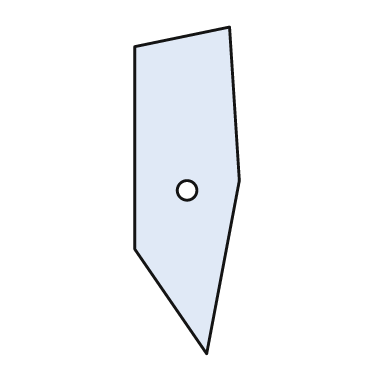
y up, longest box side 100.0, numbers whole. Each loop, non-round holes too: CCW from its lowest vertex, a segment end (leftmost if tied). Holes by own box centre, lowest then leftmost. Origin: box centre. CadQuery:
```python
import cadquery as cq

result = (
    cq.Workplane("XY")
    .moveTo(6.0, -50.0)
    .lineTo(16.0, 3.0)
    .lineTo(13.0, 50.0)
    .lineTo(-16.0, 44.0)
    .lineTo(-16.0, -18.0)
    .close()
    .moveTo(0.0, 0.0)
    .circle(3.0)
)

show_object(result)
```